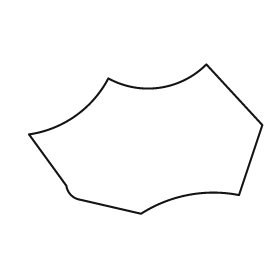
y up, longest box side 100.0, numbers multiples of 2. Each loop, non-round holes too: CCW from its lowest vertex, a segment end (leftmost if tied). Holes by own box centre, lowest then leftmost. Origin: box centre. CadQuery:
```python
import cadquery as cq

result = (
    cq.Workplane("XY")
    .moveTo(-2.0, -32.0)
    .threePointArc((18.0, -24.0), (40.0, -24.0))
    .lineTo(50.0, 6.0)
    .lineTo(26.0, 32.0)
    .threePointArc((6.0, 22.0), (-16.0, 26.0))
    .threePointArc((-30.0, 10.0), (-50.0, 2.0))
    .lineTo(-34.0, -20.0)
    .threePointArc((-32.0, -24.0), (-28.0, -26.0))
    .close()
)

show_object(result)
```